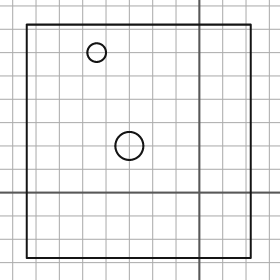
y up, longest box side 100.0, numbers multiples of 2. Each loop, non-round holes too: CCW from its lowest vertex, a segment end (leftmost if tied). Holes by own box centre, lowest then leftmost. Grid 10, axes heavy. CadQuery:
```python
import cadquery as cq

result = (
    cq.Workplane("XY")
    .moveTo(-74.0, -28.0)
    .lineTo(22.0, -28.0)
    .lineTo(22.0, 72.0)
    .lineTo(-74.0, 72.0)
    .close()
    .moveTo(-30.0, 20.0)
    .circle(6.0)
    .moveTo(-44.0, 60.0)
    .circle(4.0)
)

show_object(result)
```